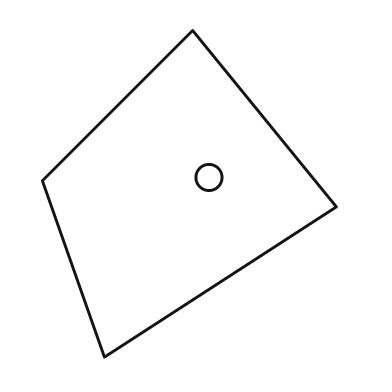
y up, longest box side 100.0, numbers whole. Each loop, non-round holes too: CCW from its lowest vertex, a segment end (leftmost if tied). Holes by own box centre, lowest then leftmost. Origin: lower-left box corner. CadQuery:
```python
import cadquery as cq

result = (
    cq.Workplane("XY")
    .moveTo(19.0, 0.0)
    .lineTo(90.0, 46.0)
    .lineTo(46.0, 100.0)
    .lineTo(0.0, 54.0)
    .close()
    .moveTo(51.0, 55.0)
    .circle(4.0)
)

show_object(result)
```